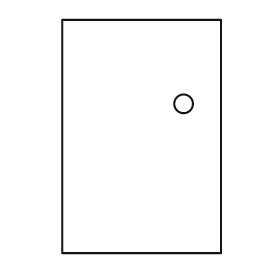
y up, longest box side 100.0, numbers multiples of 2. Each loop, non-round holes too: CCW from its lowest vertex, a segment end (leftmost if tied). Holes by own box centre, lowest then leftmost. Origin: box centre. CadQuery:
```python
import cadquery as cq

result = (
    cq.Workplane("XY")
    .moveTo(-34.0, -50.0)
    .lineTo(34.0, -50.0)
    .lineTo(34.0, 50.0)
    .lineTo(-34.0, 50.0)
    .close()
    .moveTo(18.0, 14.0)
    .circle(4.0)
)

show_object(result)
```